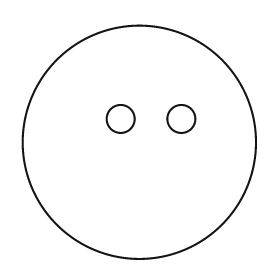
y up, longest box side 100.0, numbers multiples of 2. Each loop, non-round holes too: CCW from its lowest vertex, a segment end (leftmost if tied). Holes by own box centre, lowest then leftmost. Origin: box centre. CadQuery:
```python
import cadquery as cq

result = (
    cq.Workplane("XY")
    .moveTo(0.0, 0.0)
    .circle(50.0)
    .moveTo(-8.0, 10.0)
    .circle(6.0)
    .moveTo(18.0, 10.0)
    .circle(6.0)
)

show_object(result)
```